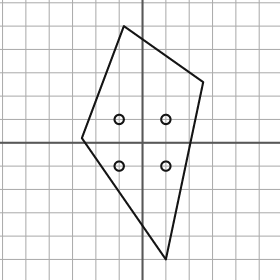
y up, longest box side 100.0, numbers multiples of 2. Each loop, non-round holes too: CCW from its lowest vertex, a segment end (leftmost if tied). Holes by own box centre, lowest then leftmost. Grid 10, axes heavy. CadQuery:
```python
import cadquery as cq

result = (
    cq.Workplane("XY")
    .moveTo(10.0, -50.0)
    .lineTo(26.0, 26.0)
    .lineTo(-8.0, 50.0)
    .lineTo(-26.0, 2.0)
    .close()
    .moveTo(-10.0, -10.0)
    .circle(2.0)
    .moveTo(10.0, -10.0)
    .circle(2.0)
    .moveTo(-10.0, 10.0)
    .circle(2.0)
    .moveTo(10.0, 10.0)
    .circle(2.0)
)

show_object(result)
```